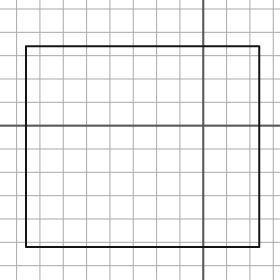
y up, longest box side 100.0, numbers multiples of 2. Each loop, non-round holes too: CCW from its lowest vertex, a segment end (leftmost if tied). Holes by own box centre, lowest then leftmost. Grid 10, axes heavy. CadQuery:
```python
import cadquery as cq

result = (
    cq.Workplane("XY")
    .moveTo(-76.0, -52.0)
    .lineTo(24.0, -52.0)
    .lineTo(24.0, 34.0)
    .lineTo(-76.0, 34.0)
    .close()
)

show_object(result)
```